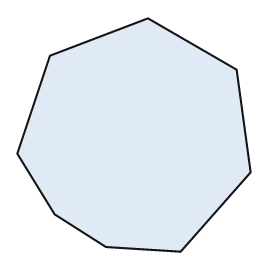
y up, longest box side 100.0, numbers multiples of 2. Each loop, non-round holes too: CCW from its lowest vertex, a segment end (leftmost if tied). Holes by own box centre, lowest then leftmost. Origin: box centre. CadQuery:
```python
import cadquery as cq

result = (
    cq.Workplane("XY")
    .moveTo(20.0, -50.0)
    .lineTo(50.0, -16.0)
    .lineTo(44.0, 28.0)
    .lineTo(6.0, 50.0)
    .lineTo(-36.0, 34.0)
    .lineTo(-50.0, -8.0)
    .lineTo(-34.0, -34.0)
    .lineTo(-12.0, -48.0)
    .close()
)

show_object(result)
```